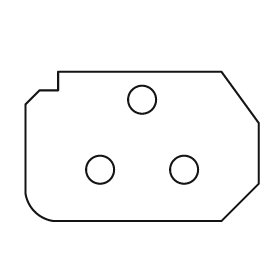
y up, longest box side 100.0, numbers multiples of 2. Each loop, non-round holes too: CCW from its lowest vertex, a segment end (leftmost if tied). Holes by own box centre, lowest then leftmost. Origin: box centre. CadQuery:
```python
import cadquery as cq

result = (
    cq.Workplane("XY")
    .moveTo(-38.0, -32.0)
    .lineTo(34.0, -32.0)
    .lineTo(50.0, -16.0)
    .lineTo(50.0, 10.0)
    .lineTo(34.0, 32.0)
    .lineTo(-36.0, 32.0)
    .lineTo(-36.0, 24.0)
    .lineTo(-44.0, 24.0)
    .lineTo(-50.0, 18.0)
    .lineTo(-50.0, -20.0)
    .threePointArc((-46.0, -28.0), (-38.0, -32.0))
    .close()
    .moveTo(-18.0, -10.0)
    .circle(6.0)
    .moveTo(18.0, -10.0)
    .circle(6.0)
    .moveTo(0.0, 20.0)
    .circle(6.0)
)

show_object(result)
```